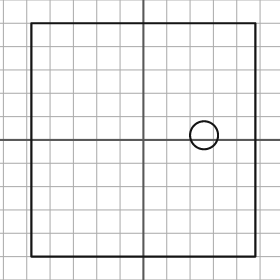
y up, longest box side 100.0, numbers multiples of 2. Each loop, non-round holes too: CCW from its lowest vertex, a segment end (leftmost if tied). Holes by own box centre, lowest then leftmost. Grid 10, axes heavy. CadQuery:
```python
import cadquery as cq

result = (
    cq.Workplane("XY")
    .moveTo(-48.0, -50.0)
    .lineTo(48.0, -50.0)
    .lineTo(48.0, 50.0)
    .lineTo(-48.0, 50.0)
    .close()
    .moveTo(26.0, 2.0)
    .circle(6.0)
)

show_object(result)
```